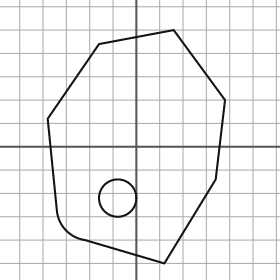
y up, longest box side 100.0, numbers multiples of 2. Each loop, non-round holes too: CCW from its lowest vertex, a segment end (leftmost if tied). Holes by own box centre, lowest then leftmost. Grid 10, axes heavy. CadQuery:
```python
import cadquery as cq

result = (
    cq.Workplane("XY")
    .moveTo(12.0, -50.0)
    .lineTo(34.0, -14.0)
    .lineTo(38.0, 20.0)
    .lineTo(16.0, 50.0)
    .lineTo(-16.0, 44.0)
    .lineTo(-38.0, 12.0)
    .lineTo(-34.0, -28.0)
    .threePointArc((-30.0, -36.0), (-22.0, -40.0))
    .close()
    .moveTo(-8.0, -22.0)
    .circle(8.0)
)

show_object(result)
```